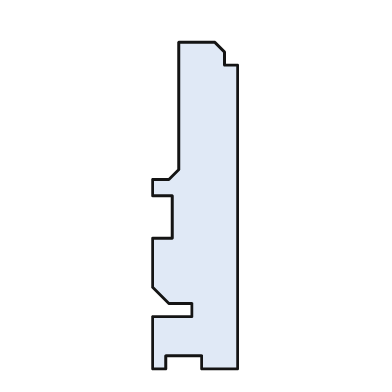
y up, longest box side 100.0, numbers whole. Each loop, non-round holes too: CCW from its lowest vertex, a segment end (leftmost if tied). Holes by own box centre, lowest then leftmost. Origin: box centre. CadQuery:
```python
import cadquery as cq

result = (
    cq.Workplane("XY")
    .moveTo(-13.0, -50.0)
    .lineTo(-9.0, -50.0)
    .lineTo(-9.0, -46.0)
    .lineTo(2.0, -46.0)
    .lineTo(2.0, -50.0)
    .lineTo(13.0, -50.0)
    .lineTo(13.0, 43.0)
    .lineTo(9.0, 43.0)
    .lineTo(9.0, 47.0)
    .lineTo(6.0, 50.0)
    .lineTo(-5.0, 50.0)
    .lineTo(-5.0, 11.0)
    .lineTo(-8.0, 8.0)
    .lineTo(-13.0, 8.0)
    .lineTo(-13.0, 3.0)
    .lineTo(-7.0, 3.0)
    .lineTo(-7.0, -10.0)
    .lineTo(-13.0, -10.0)
    .lineTo(-13.0, -25.0)
    .lineTo(-8.0, -30.0)
    .lineTo(-1.0, -30.0)
    .lineTo(-1.0, -34.0)
    .lineTo(-13.0, -34.0)
    .close()
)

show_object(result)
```